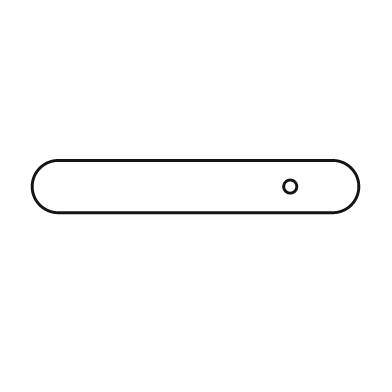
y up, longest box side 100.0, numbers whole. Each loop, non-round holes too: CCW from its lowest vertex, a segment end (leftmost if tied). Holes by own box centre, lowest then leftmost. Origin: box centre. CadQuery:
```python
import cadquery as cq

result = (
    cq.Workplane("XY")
    .moveTo(-42.0, -8.0)
    .lineTo(42.0, -8.0)
    .threePointArc((50.0, 0.0), (42.0, 8.0))
    .lineTo(-42.0, 8.0)
    .threePointArc((-50.0, 0.0), (-42.0, -8.0))
    .close()
    .moveTo(29.0, 0.0)
    .circle(2.0)
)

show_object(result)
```